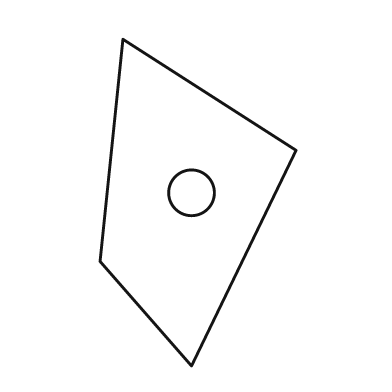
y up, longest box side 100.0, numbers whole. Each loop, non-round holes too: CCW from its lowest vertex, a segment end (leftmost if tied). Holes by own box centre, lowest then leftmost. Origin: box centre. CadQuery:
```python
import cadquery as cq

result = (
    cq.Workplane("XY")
    .moveTo(-2.0, -50.0)
    .lineTo(30.0, 16.0)
    .lineTo(-23.0, 50.0)
    .lineTo(-30.0, -18.0)
    .close()
    .moveTo(-2.0, 3.0)
    .circle(7.0)
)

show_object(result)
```